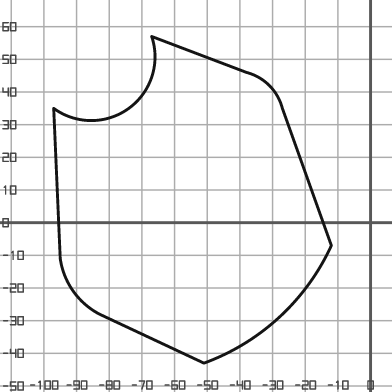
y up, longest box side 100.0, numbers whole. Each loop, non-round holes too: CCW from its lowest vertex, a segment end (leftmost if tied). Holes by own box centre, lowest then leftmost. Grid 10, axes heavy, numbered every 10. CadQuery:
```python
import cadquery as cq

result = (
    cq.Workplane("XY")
    .moveTo(-51.0, -43.0)
    .threePointArc((-28.0, -29.0), (-12.0, -7.0))
    .lineTo(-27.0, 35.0)
    .threePointArc((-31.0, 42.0), (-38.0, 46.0))
    .lineTo(-67.0, 57.0)
    .threePointArc((-74.0, 35.0), (-97.0, 35.0))
    .lineTo(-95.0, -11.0)
    .threePointArc((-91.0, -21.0), (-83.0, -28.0))
    .close()
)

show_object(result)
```